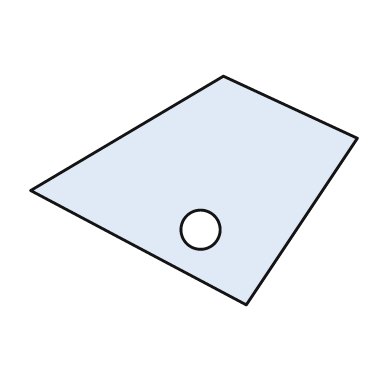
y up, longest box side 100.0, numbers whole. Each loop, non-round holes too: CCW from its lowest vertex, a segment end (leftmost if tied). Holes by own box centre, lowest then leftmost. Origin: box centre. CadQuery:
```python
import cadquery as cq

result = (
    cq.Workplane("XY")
    .moveTo(16.0, -35.0)
    .lineTo(50.0, 16.0)
    .lineTo(9.0, 35.0)
    .lineTo(-50.0, 0.0)
    .close()
    .moveTo(2.0, -12.0)
    .circle(6.0)
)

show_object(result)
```